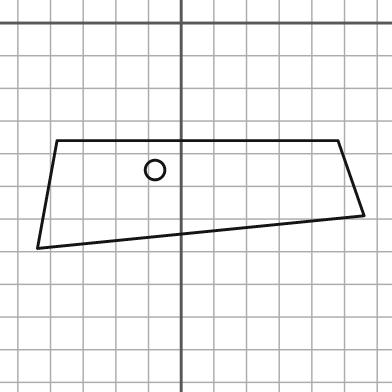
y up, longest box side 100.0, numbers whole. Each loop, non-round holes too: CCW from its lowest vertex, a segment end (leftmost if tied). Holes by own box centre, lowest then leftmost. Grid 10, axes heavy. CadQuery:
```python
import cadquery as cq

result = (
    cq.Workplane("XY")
    .moveTo(-44.0, -69.0)
    .lineTo(56.0, -59.0)
    .lineTo(48.0, -36.0)
    .lineTo(-38.0, -36.0)
    .close()
    .moveTo(-8.0, -45.0)
    .circle(3.0)
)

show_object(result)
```